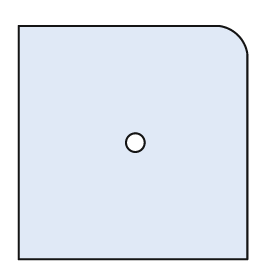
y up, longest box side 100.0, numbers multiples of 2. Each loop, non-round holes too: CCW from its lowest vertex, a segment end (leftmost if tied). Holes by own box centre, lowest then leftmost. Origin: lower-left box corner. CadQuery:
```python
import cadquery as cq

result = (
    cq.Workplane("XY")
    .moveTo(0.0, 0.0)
    .lineTo(98.0, 0.0)
    .lineTo(98.0, 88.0)
    .threePointArc((94.0, 96.0), (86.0, 100.0))
    .lineTo(0.0, 100.0)
    .close()
    .moveTo(50.0, 50.0)
    .circle(4.0)
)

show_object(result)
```